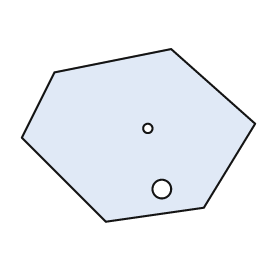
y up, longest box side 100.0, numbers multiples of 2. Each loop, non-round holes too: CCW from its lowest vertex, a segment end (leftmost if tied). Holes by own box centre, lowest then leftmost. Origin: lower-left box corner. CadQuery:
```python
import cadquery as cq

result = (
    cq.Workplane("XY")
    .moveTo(36.0, 0.0)
    .lineTo(78.0, 6.0)
    .lineTo(100.0, 42.0)
    .lineTo(64.0, 74.0)
    .lineTo(14.0, 64.0)
    .lineTo(0.0, 36.0)
    .close()
    .moveTo(60.0, 14.0)
    .circle(4.0)
    .moveTo(54.0, 40.0)
    .circle(2.0)
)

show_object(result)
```